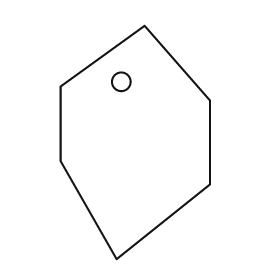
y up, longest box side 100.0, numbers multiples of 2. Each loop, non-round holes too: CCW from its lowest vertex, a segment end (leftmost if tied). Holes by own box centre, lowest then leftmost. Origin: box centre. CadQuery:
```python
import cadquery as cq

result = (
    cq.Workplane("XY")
    .moveTo(-8.0, -50.0)
    .lineTo(32.0, -18.0)
    .lineTo(32.0, 18.0)
    .lineTo(4.0, 50.0)
    .lineTo(-32.0, 24.0)
    .lineTo(-32.0, -8.0)
    .close()
    .moveTo(-6.0, 26.0)
    .circle(4.0)
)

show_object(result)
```